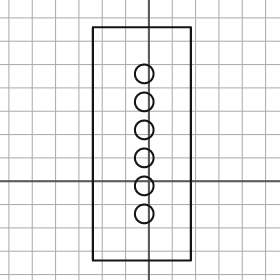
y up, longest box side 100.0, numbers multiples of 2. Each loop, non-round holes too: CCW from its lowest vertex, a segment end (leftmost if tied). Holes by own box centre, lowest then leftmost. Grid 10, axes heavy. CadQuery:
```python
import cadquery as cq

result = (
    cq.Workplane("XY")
    .moveTo(-24.0, -34.0)
    .lineTo(18.0, -34.0)
    .lineTo(18.0, 66.0)
    .lineTo(-24.0, 66.0)
    .close()
    .moveTo(-2.0, -14.0)
    .circle(4.0)
    .moveTo(-2.0, -2.0)
    .circle(4.0)
    .moveTo(-2.0, 10.0)
    .circle(4.0)
    .moveTo(-2.0, 22.0)
    .circle(4.0)
    .moveTo(-2.0, 34.0)
    .circle(4.0)
    .moveTo(-2.0, 46.0)
    .circle(4.0)
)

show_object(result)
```